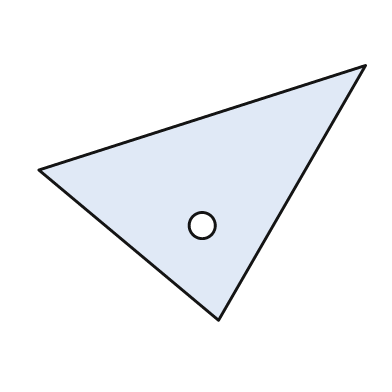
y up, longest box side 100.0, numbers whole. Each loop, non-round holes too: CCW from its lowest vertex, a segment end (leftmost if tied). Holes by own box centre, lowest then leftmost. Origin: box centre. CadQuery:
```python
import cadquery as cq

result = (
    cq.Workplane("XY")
    .moveTo(5.0, -39.0)
    .lineTo(50.0, 39.0)
    .lineTo(-50.0, 7.0)
    .close()
    .moveTo(0.0, -10.0)
    .circle(4.0)
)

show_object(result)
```